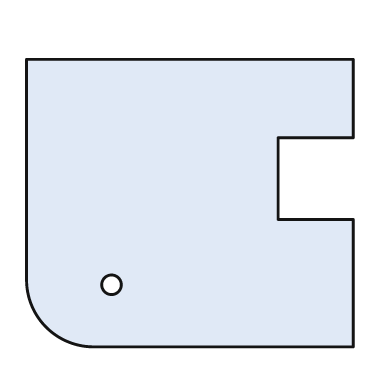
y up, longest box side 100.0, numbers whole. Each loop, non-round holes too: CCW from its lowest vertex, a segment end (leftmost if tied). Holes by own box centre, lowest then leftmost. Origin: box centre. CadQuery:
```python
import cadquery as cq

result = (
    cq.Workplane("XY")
    .moveTo(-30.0, -44.0)
    .lineTo(50.0, -44.0)
    .lineTo(50.0, -5.0)
    .lineTo(27.0, -5.0)
    .lineTo(27.0, 20.0)
    .lineTo(50.0, 20.0)
    .lineTo(50.0, 44.0)
    .lineTo(-50.0, 44.0)
    .lineTo(-50.0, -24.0)
    .threePointArc((-44.0, -38.0), (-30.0, -44.0))
    .close()
    .moveTo(-24.0, -25.0)
    .circle(3.0)
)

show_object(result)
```